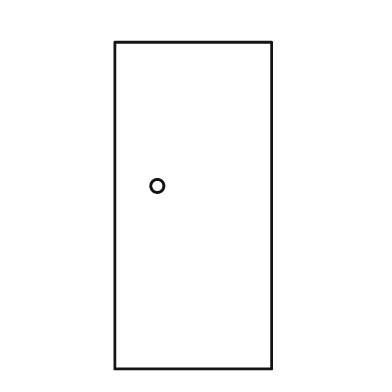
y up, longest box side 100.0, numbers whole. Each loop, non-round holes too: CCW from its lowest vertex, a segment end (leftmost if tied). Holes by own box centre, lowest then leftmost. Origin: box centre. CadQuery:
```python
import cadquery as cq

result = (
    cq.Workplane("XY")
    .moveTo(-24.0, -50.0)
    .lineTo(24.0, -50.0)
    .lineTo(24.0, 50.0)
    .lineTo(-24.0, 50.0)
    .close()
    .moveTo(-11.0, 6.0)
    .circle(2.0)
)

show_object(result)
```